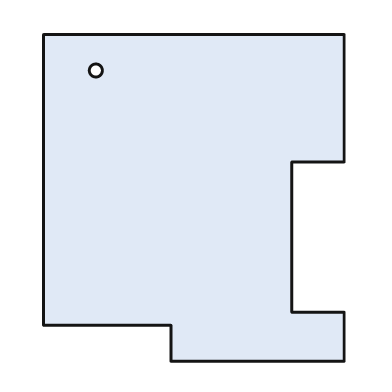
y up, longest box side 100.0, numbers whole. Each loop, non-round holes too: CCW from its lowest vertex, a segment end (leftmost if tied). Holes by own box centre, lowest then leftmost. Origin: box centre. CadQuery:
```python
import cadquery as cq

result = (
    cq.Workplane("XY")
    .moveTo(-7.0, -50.0)
    .lineTo(46.0, -50.0)
    .lineTo(46.0, -35.0)
    .lineTo(30.0, -35.0)
    .lineTo(30.0, 11.0)
    .lineTo(46.0, 11.0)
    .lineTo(46.0, 50.0)
    .lineTo(-46.0, 50.0)
    .lineTo(-46.0, -39.0)
    .lineTo(-7.0, -39.0)
    .close()
    .moveTo(-30.0, 39.0)
    .circle(2.0)
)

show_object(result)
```